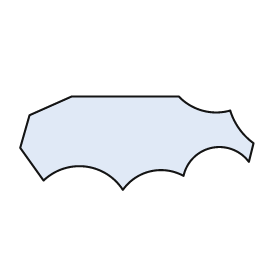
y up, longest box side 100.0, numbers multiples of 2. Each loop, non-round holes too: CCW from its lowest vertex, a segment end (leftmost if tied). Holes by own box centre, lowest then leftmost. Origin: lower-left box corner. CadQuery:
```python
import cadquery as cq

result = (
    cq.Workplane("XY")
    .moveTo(44.0, 0.0)
    .threePointArc((56.0, 8.0), (70.0, 6.0))
    .threePointArc((82.0, 18.0), (98.0, 12.0))
    .lineTo(100.0, 20.0)
    .threePointArc((94.0, 26.0), (90.0, 34.0))
    .threePointArc((78.0, 34.0), (68.0, 40.0))
    .lineTo(22.0, 40.0)
    .lineTo(4.0, 32.0)
    .lineTo(0.0, 18.0)
    .lineTo(10.0, 4.0)
    .threePointArc((28.0, 10.0), (44.0, 0.0))
    .close()
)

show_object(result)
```